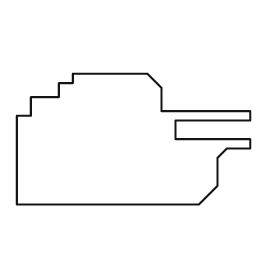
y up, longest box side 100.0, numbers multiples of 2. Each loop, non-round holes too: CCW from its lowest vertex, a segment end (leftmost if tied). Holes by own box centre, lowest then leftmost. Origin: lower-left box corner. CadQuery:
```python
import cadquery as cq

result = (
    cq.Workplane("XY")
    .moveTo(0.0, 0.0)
    .lineTo(78.0, 0.0)
    .lineTo(86.0, 8.0)
    .lineTo(86.0, 20.0)
    .lineTo(90.0, 24.0)
    .lineTo(100.0, 24.0)
    .lineTo(100.0, 28.0)
    .lineTo(68.0, 28.0)
    .lineTo(68.0, 36.0)
    .lineTo(100.0, 36.0)
    .lineTo(100.0, 40.0)
    .lineTo(62.0, 40.0)
    .lineTo(62.0, 50.0)
    .lineTo(56.0, 56.0)
    .lineTo(24.0, 56.0)
    .lineTo(24.0, 52.0)
    .lineTo(18.0, 52.0)
    .lineTo(18.0, 46.0)
    .lineTo(6.0, 46.0)
    .lineTo(6.0, 38.0)
    .lineTo(0.0, 38.0)
    .close()
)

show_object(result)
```